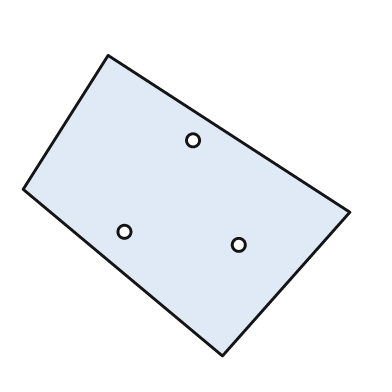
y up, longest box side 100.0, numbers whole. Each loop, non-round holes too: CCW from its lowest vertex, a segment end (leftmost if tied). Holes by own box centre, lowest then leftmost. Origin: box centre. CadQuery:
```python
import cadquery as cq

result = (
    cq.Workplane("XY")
    .moveTo(11.0, -46.0)
    .lineTo(50.0, -2.0)
    .lineTo(-24.0, 46.0)
    .lineTo(-50.0, 5.0)
    .close()
    .moveTo(16.0, -12.0)
    .circle(2.0)
    .moveTo(-19.0, -8.0)
    .circle(2.0)
    .moveTo(2.0, 20.0)
    .circle(2.0)
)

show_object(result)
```